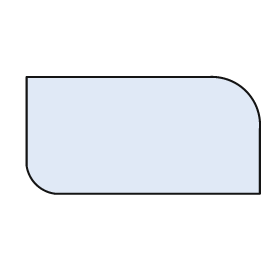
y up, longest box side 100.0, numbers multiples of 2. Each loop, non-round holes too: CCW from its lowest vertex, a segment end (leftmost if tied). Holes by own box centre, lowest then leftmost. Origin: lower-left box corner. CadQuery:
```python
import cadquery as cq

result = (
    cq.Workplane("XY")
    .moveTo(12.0, 0.0)
    .lineTo(100.0, 0.0)
    .lineTo(100.0, 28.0)
    .threePointArc((94.0, 44.0), (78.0, 50.0))
    .lineTo(0.0, 50.0)
    .lineTo(0.0, 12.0)
    .threePointArc((4.0, 4.0), (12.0, 0.0))
    .close()
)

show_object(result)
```